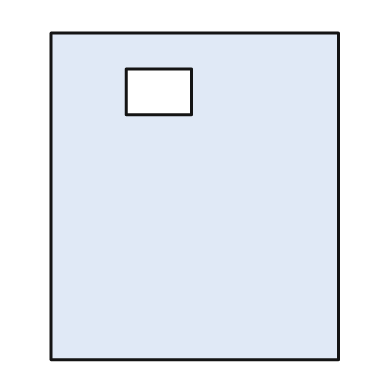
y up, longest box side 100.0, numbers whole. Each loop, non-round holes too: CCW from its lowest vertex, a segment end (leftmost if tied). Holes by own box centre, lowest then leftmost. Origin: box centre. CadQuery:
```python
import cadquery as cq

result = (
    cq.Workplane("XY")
    .moveTo(-44.0, -50.0)
    .lineTo(44.0, -50.0)
    .lineTo(44.0, 50.0)
    .lineTo(-44.0, 50.0)
    .close()
    .moveTo(-21.0, 25.0)
    .lineTo(-1.0, 25.0)
    .lineTo(-1.0, 39.0)
    .lineTo(-21.0, 39.0)
    .close()
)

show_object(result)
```